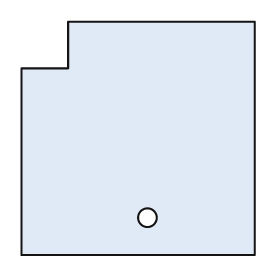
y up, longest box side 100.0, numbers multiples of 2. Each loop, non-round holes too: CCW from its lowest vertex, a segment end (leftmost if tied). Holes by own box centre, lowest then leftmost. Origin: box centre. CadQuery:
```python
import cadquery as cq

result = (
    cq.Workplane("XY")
    .moveTo(-50.0, -50.0)
    .lineTo(50.0, -50.0)
    .lineTo(50.0, 50.0)
    .lineTo(-30.0, 50.0)
    .lineTo(-30.0, 30.0)
    .lineTo(-50.0, 30.0)
    .close()
    .moveTo(4.0, -34.0)
    .circle(4.0)
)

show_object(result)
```